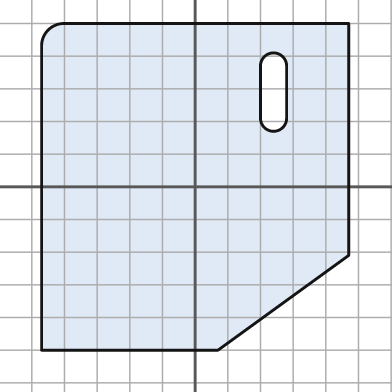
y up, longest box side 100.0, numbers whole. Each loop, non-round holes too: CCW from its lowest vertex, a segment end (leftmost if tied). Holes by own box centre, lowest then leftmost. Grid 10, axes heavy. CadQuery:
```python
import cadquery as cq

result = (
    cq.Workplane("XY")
    .moveTo(-47.0, -50.0)
    .lineTo(7.0, -50.0)
    .lineTo(47.0, -21.0)
    .lineTo(47.0, 50.0)
    .lineTo(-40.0, 50.0)
    .threePointArc((-45.0, 48.0), (-47.0, 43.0))
    .close()
    .moveTo(20.0, 21.0)
    .threePointArc((24.0, 17.0), (28.0, 21.0))
    .lineTo(28.0, 37.0)
    .threePointArc((24.0, 41.0), (20.0, 37.0))
    .close()
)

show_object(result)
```